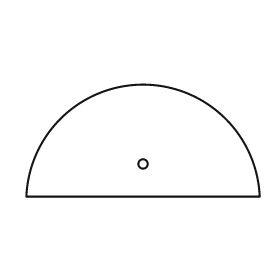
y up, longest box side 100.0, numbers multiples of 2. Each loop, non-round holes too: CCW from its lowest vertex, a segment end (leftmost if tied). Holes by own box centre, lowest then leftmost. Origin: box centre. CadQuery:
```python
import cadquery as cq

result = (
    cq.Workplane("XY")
    .moveTo(-50.0, -24.0)
    .lineTo(50.0, -24.0)
    .threePointArc((0.0, 24.0), (-50.0, -24.0))
    .close()
    .moveTo(0.0, -10.0)
    .circle(2.0)
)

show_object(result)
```